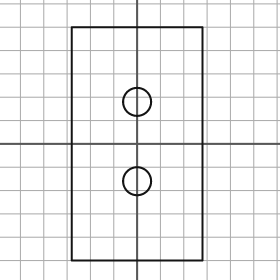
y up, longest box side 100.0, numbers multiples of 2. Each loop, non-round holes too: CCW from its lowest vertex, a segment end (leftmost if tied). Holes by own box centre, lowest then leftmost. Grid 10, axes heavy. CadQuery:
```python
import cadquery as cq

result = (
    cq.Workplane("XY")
    .moveTo(-28.0, -50.0)
    .lineTo(28.0, -50.0)
    .lineTo(28.0, 50.0)
    .lineTo(-28.0, 50.0)
    .close()
    .moveTo(0.0, -16.0)
    .circle(6.0)
    .moveTo(0.0, 18.0)
    .circle(6.0)
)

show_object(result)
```